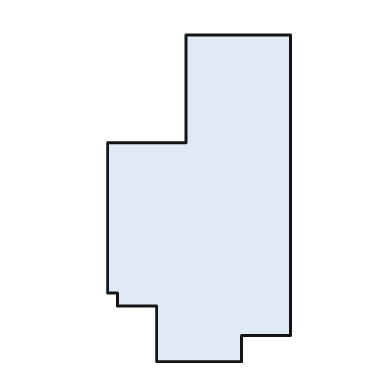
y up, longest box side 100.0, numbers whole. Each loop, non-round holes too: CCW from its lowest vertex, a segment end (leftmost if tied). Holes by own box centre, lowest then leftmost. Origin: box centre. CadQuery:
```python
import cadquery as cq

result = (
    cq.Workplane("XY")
    .moveTo(-13.0, -50.0)
    .lineTo(13.0, -50.0)
    .lineTo(13.0, -42.0)
    .lineTo(28.0, -42.0)
    .lineTo(28.0, 50.0)
    .lineTo(-4.0, 50.0)
    .lineTo(-4.0, 17.0)
    .lineTo(-28.0, 17.0)
    .lineTo(-28.0, -29.0)
    .lineTo(-25.0, -29.0)
    .lineTo(-25.0, -33.0)
    .lineTo(-13.0, -33.0)
    .close()
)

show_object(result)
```